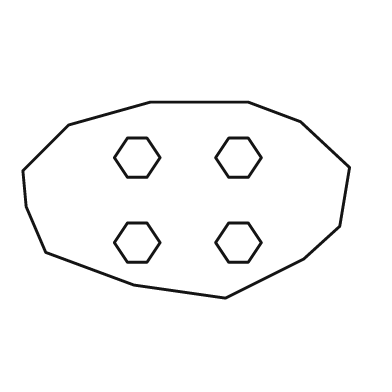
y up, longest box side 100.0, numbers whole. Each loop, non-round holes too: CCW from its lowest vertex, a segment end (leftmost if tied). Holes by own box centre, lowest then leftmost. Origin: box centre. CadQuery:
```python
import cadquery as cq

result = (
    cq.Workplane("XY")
    .moveTo(12.0, -30.0)
    .lineTo(36.0, -18.0)
    .lineTo(47.0, -8.0)
    .lineTo(50.0, 10.0)
    .lineTo(35.0, 24.0)
    .lineTo(19.0, 30.0)
    .lineTo(-11.0, 30.0)
    .lineTo(-36.0, 23.0)
    .lineTo(-50.0, 9.0)
    .lineTo(-49.0, -2.0)
    .lineTo(-43.0, -16.0)
    .lineTo(-16.0, -26.0)
    .close()
    .moveTo(-18.0, -19.0)
    .lineTo(-12.0, -19.0)
    .lineTo(-8.0, -13.0)
    .lineTo(-12.0, -7.0)
    .lineTo(-18.0, -7.0)
    .lineTo(-22.0, -13.0)
    .close()
    .moveTo(13.0, -19.0)
    .lineTo(19.0, -19.0)
    .lineTo(23.0, -13.0)
    .lineTo(19.0, -7.0)
    .lineTo(13.0, -7.0)
    .lineTo(9.0, -13.0)
    .close()
    .moveTo(-18.0, 7.0)
    .lineTo(-12.0, 7.0)
    .lineTo(-8.0, 13.0)
    .lineTo(-12.0, 19.0)
    .lineTo(-18.0, 19.0)
    .lineTo(-22.0, 13.0)
    .close()
    .moveTo(13.0, 7.0)
    .lineTo(19.0, 7.0)
    .lineTo(23.0, 13.0)
    .lineTo(19.0, 19.0)
    .lineTo(13.0, 19.0)
    .lineTo(9.0, 13.0)
    .close()
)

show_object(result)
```